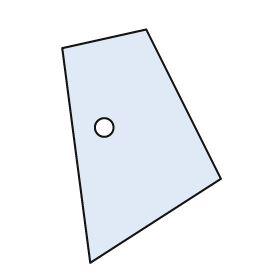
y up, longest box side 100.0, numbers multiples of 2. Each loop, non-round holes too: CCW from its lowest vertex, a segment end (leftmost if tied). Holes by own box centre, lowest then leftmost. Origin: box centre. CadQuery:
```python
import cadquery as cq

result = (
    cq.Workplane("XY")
    .moveTo(-22.0, -50.0)
    .lineTo(34.0, -14.0)
    .lineTo(2.0, 50.0)
    .lineTo(-34.0, 42.0)
    .close()
    .moveTo(-16.0, 8.0)
    .circle(4.0)
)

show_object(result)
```